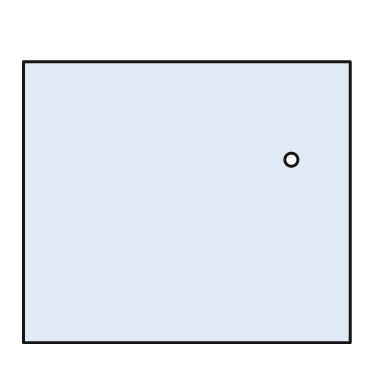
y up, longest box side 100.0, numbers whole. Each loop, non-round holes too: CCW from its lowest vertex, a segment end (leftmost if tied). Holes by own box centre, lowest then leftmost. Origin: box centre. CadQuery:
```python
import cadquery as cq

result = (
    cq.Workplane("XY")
    .moveTo(-50.0, -43.0)
    .lineTo(50.0, -43.0)
    .lineTo(50.0, 43.0)
    .lineTo(-50.0, 43.0)
    .close()
    .moveTo(32.0, 13.0)
    .circle(2.0)
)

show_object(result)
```